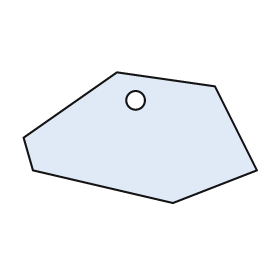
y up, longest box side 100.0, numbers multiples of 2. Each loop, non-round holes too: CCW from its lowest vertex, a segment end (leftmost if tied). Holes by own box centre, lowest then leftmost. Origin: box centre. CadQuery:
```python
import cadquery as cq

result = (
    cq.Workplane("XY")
    .moveTo(14.0, -28.0)
    .lineTo(50.0, -14.0)
    .lineTo(32.0, 22.0)
    .lineTo(-10.0, 28.0)
    .lineTo(-50.0, 0.0)
    .lineTo(-46.0, -14.0)
    .close()
    .moveTo(-2.0, 16.0)
    .circle(4.0)
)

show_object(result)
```